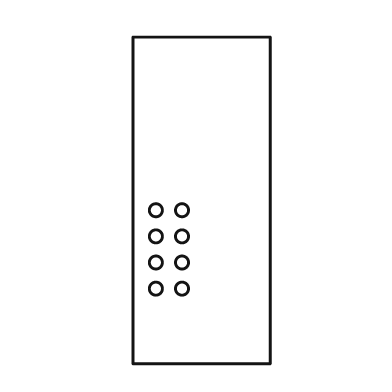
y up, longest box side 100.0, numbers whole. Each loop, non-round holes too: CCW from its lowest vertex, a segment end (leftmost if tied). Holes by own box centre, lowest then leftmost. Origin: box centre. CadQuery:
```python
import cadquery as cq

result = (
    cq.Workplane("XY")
    .moveTo(-21.0, -50.0)
    .lineTo(21.0, -50.0)
    .lineTo(21.0, 50.0)
    .lineTo(-21.0, 50.0)
    .close()
    .moveTo(-14.0, -27.0)
    .circle(2.0)
    .moveTo(-6.0, -27.0)
    .circle(2.0)
    .moveTo(-14.0, -19.0)
    .circle(2.0)
    .moveTo(-6.0, -19.0)
    .circle(2.0)
    .moveTo(-14.0, -11.0)
    .circle(2.0)
    .moveTo(-6.0, -11.0)
    .circle(2.0)
    .moveTo(-14.0, -3.0)
    .circle(2.0)
    .moveTo(-6.0, -3.0)
    .circle(2.0)
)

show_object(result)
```